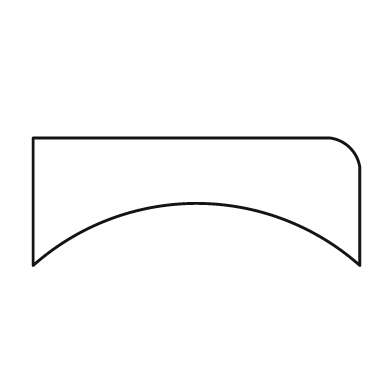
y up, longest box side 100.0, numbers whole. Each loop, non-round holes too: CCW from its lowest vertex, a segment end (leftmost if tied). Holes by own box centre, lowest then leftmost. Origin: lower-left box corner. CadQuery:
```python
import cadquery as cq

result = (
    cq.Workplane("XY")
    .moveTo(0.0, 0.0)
    .threePointArc((50.0, 19.0), (100.0, 0.0))
    .lineTo(100.0, 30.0)
    .threePointArc((97.0, 36.0), (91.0, 39.0))
    .lineTo(0.0, 39.0)
    .close()
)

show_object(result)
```